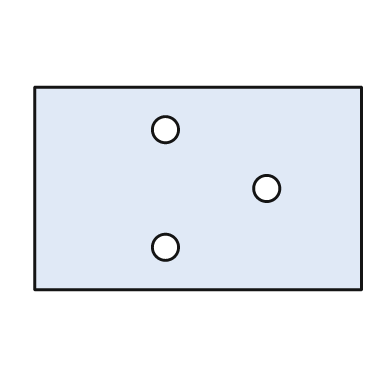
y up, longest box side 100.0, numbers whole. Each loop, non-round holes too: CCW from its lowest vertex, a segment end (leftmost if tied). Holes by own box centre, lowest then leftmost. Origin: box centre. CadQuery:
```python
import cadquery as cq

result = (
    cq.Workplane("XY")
    .moveTo(-50.0, -31.0)
    .lineTo(50.0, -31.0)
    .lineTo(50.0, 31.0)
    .lineTo(-50.0, 31.0)
    .close()
    .moveTo(-10.0, -18.0)
    .circle(4.0)
    .moveTo(21.0, 0.0)
    .circle(4.0)
    .moveTo(-10.0, 18.0)
    .circle(4.0)
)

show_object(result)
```